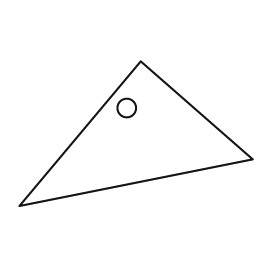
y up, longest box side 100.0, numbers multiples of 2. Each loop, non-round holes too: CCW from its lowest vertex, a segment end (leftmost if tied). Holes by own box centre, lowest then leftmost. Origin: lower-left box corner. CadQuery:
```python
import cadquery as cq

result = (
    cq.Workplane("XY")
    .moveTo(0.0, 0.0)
    .lineTo(100.0, 20.0)
    .lineTo(52.0, 62.0)
    .close()
    .moveTo(46.0, 42.0)
    .circle(4.0)
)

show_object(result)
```